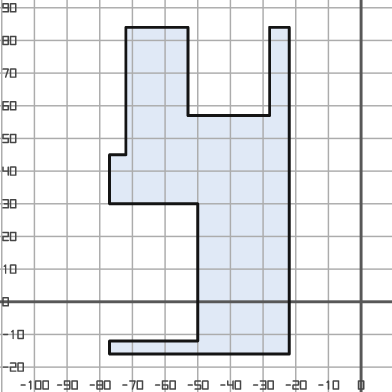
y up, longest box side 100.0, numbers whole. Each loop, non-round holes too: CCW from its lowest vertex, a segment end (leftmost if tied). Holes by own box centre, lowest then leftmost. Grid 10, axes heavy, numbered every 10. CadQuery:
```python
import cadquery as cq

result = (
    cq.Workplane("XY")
    .moveTo(-77.0, -16.0)
    .lineTo(-22.0, -16.0)
    .lineTo(-22.0, 84.0)
    .lineTo(-28.0, 84.0)
    .lineTo(-28.0, 57.0)
    .lineTo(-53.0, 57.0)
    .lineTo(-53.0, 84.0)
    .lineTo(-72.0, 84.0)
    .lineTo(-72.0, 45.0)
    .lineTo(-77.0, 45.0)
    .lineTo(-77.0, 30.0)
    .lineTo(-50.0, 30.0)
    .lineTo(-50.0, -12.0)
    .lineTo(-77.0, -12.0)
    .close()
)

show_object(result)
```